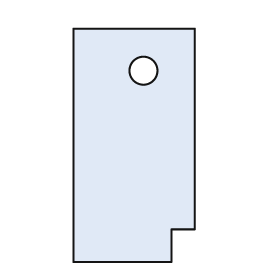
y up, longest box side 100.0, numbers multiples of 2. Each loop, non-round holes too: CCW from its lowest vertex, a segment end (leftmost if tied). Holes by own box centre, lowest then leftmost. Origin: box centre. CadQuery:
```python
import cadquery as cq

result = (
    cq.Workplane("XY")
    .moveTo(-26.0, -50.0)
    .lineTo(16.0, -50.0)
    .lineTo(16.0, -36.0)
    .lineTo(26.0, -36.0)
    .lineTo(26.0, 50.0)
    .lineTo(-26.0, 50.0)
    .close()
    .moveTo(4.0, 32.0)
    .circle(6.0)
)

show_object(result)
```